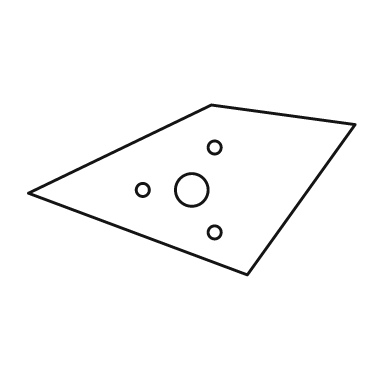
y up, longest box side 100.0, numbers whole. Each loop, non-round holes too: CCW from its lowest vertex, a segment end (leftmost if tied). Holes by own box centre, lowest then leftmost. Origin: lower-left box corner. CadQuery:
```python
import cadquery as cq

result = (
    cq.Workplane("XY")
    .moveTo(67.0, 0.0)
    .lineTo(100.0, 46.0)
    .lineTo(56.0, 52.0)
    .lineTo(0.0, 25.0)
    .close()
    .moveTo(57.0, 13.0)
    .circle(2.0)
    .moveTo(35.0, 26.0)
    .circle(2.0)
    .moveTo(50.0, 26.0)
    .circle(5.0)
    .moveTo(57.0, 39.0)
    .circle(2.0)
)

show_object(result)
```